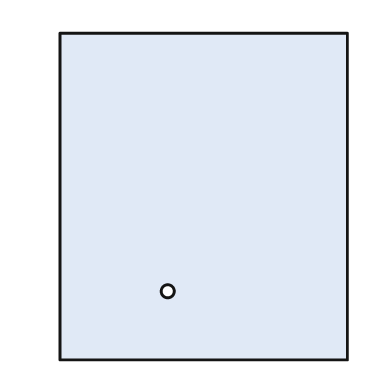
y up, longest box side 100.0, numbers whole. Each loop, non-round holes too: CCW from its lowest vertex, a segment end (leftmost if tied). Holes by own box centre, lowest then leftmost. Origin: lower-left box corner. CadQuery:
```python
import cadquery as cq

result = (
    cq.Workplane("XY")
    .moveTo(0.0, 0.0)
    .lineTo(88.0, 0.0)
    .lineTo(88.0, 100.0)
    .lineTo(0.0, 100.0)
    .close()
    .moveTo(33.0, 21.0)
    .circle(2.0)
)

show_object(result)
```